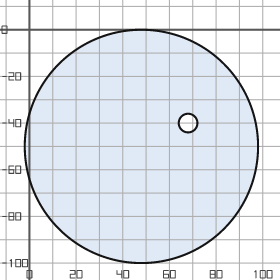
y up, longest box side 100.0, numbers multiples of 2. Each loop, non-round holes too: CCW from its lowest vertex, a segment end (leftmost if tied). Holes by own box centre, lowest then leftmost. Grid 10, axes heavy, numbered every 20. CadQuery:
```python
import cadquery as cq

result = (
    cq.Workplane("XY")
    .moveTo(48.0, -50.0)
    .circle(50.0)
    .moveTo(68.0, -40.0)
    .circle(4.0)
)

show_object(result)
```